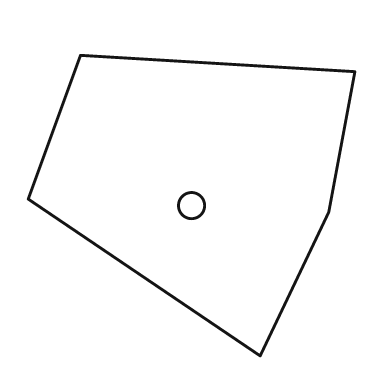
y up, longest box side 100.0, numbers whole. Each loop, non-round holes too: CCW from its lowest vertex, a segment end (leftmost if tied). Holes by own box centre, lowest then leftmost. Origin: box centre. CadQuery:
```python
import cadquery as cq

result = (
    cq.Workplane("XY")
    .moveTo(21.0, -46.0)
    .lineTo(42.0, -2.0)
    .lineTo(50.0, 41.0)
    .lineTo(-34.0, 46.0)
    .lineTo(-50.0, 2.0)
    .close()
    .moveTo(0.0, 0.0)
    .circle(4.0)
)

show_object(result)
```